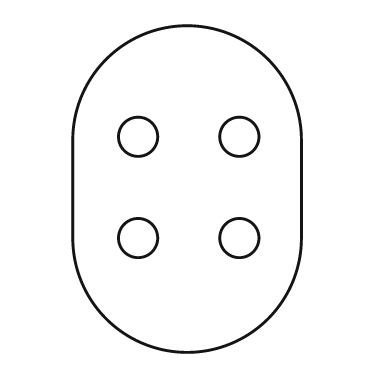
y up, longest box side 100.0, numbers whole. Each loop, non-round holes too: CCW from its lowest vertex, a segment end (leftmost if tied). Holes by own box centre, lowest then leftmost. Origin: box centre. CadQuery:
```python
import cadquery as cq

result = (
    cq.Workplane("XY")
    .moveTo(-35.0, -15.0)
    .threePointArc((0.0, -50.0), (35.0, -15.0))
    .lineTo(35.0, 15.0)
    .threePointArc((0.0, 50.0), (-35.0, 15.0))
    .close()
    .moveTo(-15.0, -15.0)
    .circle(6.0)
    .moveTo(16.0, -15.0)
    .circle(6.0)
    .moveTo(-15.0, 16.0)
    .circle(6.0)
    .moveTo(16.0, 16.0)
    .circle(6.0)
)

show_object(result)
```